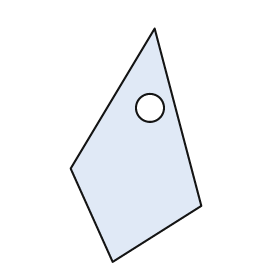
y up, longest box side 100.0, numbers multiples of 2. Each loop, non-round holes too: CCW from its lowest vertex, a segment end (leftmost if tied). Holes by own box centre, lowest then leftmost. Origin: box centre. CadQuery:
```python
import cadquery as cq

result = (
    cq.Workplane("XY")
    .moveTo(-10.0, -50.0)
    .lineTo(28.0, -26.0)
    .lineTo(8.0, 50.0)
    .lineTo(-28.0, -10.0)
    .close()
    .moveTo(6.0, 16.0)
    .circle(6.0)
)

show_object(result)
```